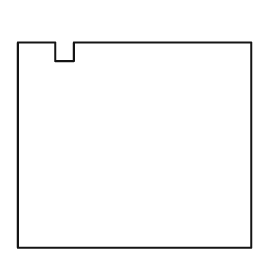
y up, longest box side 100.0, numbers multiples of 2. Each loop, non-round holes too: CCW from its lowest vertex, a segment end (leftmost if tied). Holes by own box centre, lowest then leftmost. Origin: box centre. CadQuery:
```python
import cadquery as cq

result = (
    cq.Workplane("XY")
    .moveTo(-50.0, -44.0)
    .lineTo(50.0, -44.0)
    .lineTo(50.0, 44.0)
    .lineTo(-26.0, 44.0)
    .lineTo(-26.0, 36.0)
    .lineTo(-34.0, 36.0)
    .lineTo(-34.0, 44.0)
    .lineTo(-50.0, 44.0)
    .close()
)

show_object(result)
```